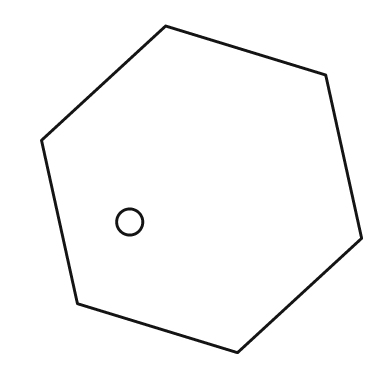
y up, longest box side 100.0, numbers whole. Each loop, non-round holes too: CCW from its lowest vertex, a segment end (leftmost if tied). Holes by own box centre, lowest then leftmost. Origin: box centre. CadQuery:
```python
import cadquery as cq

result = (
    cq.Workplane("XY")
    .moveTo(11.0, -50.0)
    .lineTo(49.0, -15.0)
    .lineTo(38.0, 35.0)
    .lineTo(-11.0, 50.0)
    .lineTo(-49.0, 15.0)
    .lineTo(-38.0, -35.0)
    .close()
    .moveTo(-22.0, -10.0)
    .circle(4.0)
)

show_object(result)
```